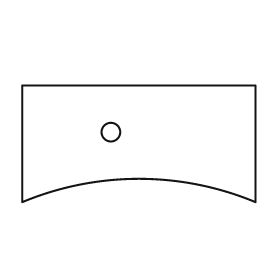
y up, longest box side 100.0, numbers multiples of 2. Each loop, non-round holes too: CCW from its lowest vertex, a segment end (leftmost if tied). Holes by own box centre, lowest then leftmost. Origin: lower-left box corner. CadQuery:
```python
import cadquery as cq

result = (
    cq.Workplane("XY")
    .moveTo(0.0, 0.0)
    .threePointArc((50.0, 10.0), (100.0, 0.0))
    .lineTo(100.0, 50.0)
    .lineTo(0.0, 50.0)
    .close()
    .moveTo(38.0, 30.0)
    .circle(4.0)
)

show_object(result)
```